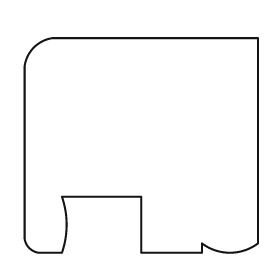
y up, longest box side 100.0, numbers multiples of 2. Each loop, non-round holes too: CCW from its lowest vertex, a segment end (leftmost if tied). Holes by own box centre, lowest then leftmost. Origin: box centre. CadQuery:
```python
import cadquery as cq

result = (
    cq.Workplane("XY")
    .moveTo(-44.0, -46.0)
    .lineTo(-34.0, -46.0)
    .threePointArc((-32.0, -34.0), (-34.0, -22.0))
    .lineTo(0.0, -22.0)
    .lineTo(0.0, -46.0)
    .lineTo(26.0, -46.0)
    .lineTo(26.0, -42.0)
    .threePointArc((38.0, -46.0), (50.0, -42.0))
    .lineTo(50.0, 46.0)
    .lineTo(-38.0, 46.0)
    .threePointArc((-46.0, 42.0), (-50.0, 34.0))
    .lineTo(-50.0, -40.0)
    .threePointArc((-48.0, -44.0), (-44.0, -46.0))
    .close()
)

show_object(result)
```